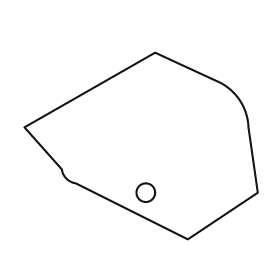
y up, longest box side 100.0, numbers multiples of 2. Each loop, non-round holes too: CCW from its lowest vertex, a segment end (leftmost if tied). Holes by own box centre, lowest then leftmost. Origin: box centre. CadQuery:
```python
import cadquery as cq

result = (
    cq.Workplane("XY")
    .moveTo(20.0, -40.0)
    .lineTo(50.0, -20.0)
    .lineTo(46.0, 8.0)
    .threePointArc((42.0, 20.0), (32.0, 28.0))
    .lineTo(6.0, 40.0)
    .lineTo(-50.0, 8.0)
    .lineTo(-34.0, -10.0)
    .threePointArc((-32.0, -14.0), (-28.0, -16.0))
    .close()
    .moveTo(2.0, -20.0)
    .circle(4.0)
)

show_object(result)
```